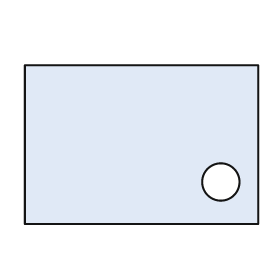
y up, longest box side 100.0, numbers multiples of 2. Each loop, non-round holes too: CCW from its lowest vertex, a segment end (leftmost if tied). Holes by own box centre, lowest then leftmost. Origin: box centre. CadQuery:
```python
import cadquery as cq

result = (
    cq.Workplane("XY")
    .moveTo(-50.0, -34.0)
    .lineTo(50.0, -34.0)
    .lineTo(50.0, 34.0)
    .lineTo(-50.0, 34.0)
    .close()
    .moveTo(34.0, -16.0)
    .circle(8.0)
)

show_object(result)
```